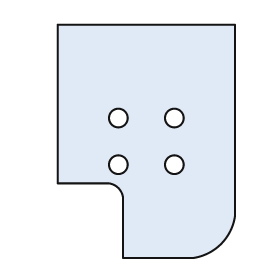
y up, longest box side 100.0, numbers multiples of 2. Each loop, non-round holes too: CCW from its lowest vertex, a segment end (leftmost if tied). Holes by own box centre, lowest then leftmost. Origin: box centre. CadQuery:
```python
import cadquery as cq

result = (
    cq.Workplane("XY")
    .moveTo(-10.0, -50.0)
    .lineTo(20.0, -50.0)
    .threePointArc((32.0, -44.0), (38.0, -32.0))
    .lineTo(38.0, 50.0)
    .lineTo(-38.0, 50.0)
    .lineTo(-38.0, -18.0)
    .lineTo(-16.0, -18.0)
    .threePointArc((-12.0, -20.0), (-10.0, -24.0))
    .close()
    .moveTo(-12.0, -10.0)
    .circle(4.0)
    .moveTo(12.0, -10.0)
    .circle(4.0)
    .moveTo(-12.0, 10.0)
    .circle(4.0)
    .moveTo(12.0, 10.0)
    .circle(4.0)
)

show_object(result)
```